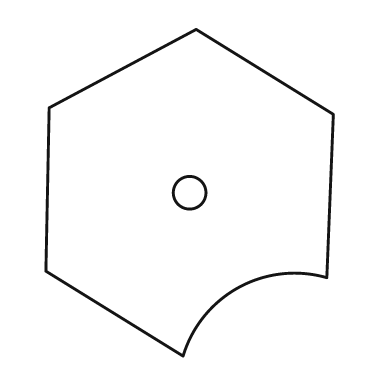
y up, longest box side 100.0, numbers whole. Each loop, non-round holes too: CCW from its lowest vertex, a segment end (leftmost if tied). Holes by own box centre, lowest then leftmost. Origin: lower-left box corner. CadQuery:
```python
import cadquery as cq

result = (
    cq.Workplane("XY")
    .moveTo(42.0, 0.0)
    .threePointArc((59.0, 21.0), (86.0, 24.0))
    .lineTo(88.0, 74.0)
    .lineTo(46.0, 100.0)
    .lineTo(1.0, 76.0)
    .lineTo(0.0, 26.0)
    .close()
    .moveTo(44.0, 50.0)
    .circle(5.0)
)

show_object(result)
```